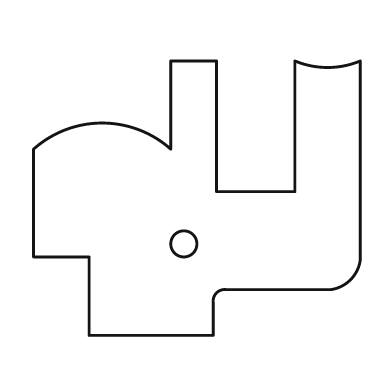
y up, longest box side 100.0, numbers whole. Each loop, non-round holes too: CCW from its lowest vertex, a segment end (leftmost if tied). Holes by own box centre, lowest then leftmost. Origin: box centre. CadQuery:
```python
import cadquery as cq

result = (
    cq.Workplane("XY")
    .moveTo(-33.0, -42.0)
    .lineTo(5.0, -42.0)
    .lineTo(5.0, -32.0)
    .threePointArc((6.0, -29.0), (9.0, -28.0))
    .lineTo(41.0, -28.0)
    .threePointArc((47.0, -25.0), (50.0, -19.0))
    .lineTo(50.0, 42.0)
    .threePointArc((40.0, 40.0), (30.0, 42.0))
    .lineTo(30.0, 2.0)
    .lineTo(6.0, 2.0)
    .lineTo(6.0, 42.0)
    .lineTo(-8.0, 42.0)
    .lineTo(-8.0, 15.0)
    .threePointArc((-29.0, 23.0), (-50.0, 15.0))
    .lineTo(-50.0, -18.0)
    .lineTo(-33.0, -18.0)
    .close()
    .moveTo(-4.0, -14.0)
    .circle(4.0)
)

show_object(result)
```